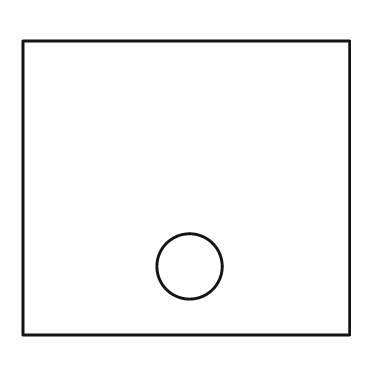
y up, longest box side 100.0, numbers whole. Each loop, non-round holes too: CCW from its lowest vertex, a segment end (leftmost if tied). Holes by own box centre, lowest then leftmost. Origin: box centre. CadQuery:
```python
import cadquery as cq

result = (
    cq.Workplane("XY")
    .moveTo(-50.0, -45.0)
    .lineTo(50.0, -45.0)
    .lineTo(50.0, 45.0)
    .lineTo(-50.0, 45.0)
    .close()
    .moveTo(1.0, -24.0)
    .circle(10.0)
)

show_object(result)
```